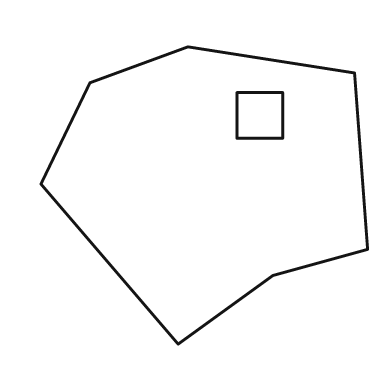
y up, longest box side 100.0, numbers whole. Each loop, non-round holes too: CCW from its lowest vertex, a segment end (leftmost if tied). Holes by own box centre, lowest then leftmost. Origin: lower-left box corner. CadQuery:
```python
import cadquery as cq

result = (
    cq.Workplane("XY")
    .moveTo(42.0, 0.0)
    .lineTo(71.0, 21.0)
    .lineTo(100.0, 29.0)
    .lineTo(96.0, 83.0)
    .lineTo(45.0, 91.0)
    .lineTo(15.0, 80.0)
    .lineTo(0.0, 49.0)
    .close()
    .moveTo(60.0, 63.0)
    .lineTo(74.0, 63.0)
    .lineTo(74.0, 77.0)
    .lineTo(60.0, 77.0)
    .close()
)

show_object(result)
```